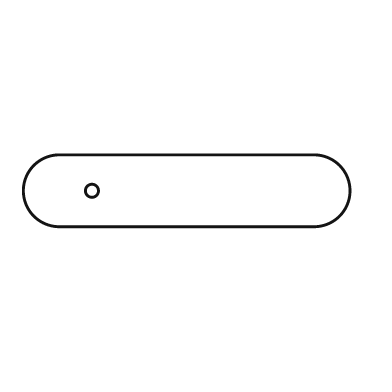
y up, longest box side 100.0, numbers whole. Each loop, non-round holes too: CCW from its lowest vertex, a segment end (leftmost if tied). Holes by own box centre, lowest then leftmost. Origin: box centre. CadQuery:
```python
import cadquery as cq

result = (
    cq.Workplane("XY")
    .moveTo(-39.0, -11.0)
    .lineTo(39.0, -11.0)
    .threePointArc((50.0, 0.0), (39.0, 11.0))
    .lineTo(-39.0, 11.0)
    .threePointArc((-50.0, 0.0), (-39.0, -11.0))
    .close()
    .moveTo(-29.0, 0.0)
    .circle(2.0)
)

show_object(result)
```